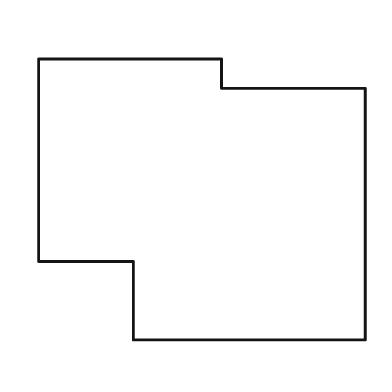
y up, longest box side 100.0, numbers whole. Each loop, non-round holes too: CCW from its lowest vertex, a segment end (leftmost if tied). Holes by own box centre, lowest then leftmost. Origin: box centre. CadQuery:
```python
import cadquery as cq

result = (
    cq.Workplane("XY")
    .moveTo(-21.0, -43.0)
    .lineTo(50.0, -43.0)
    .lineTo(50.0, 34.0)
    .lineTo(6.0, 34.0)
    .lineTo(6.0, 43.0)
    .lineTo(-50.0, 43.0)
    .lineTo(-50.0, -19.0)
    .lineTo(-21.0, -19.0)
    .close()
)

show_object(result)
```